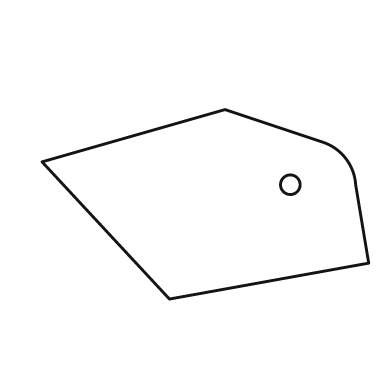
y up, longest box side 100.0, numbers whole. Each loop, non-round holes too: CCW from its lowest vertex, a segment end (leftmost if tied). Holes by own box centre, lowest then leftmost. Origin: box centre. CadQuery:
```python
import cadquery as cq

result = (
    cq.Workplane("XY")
    .moveTo(-11.0, -29.0)
    .lineTo(50.0, -18.0)
    .lineTo(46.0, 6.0)
    .threePointArc((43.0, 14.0), (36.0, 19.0))
    .lineTo(6.0, 29.0)
    .lineTo(-50.0, 13.0)
    .close()
    .moveTo(26.0, 6.0)
    .circle(3.0)
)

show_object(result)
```